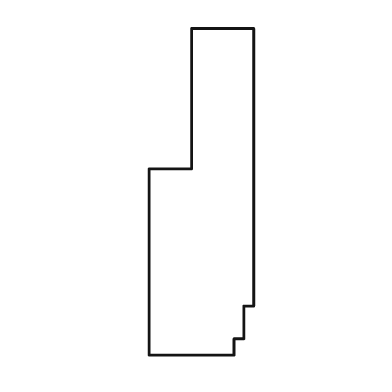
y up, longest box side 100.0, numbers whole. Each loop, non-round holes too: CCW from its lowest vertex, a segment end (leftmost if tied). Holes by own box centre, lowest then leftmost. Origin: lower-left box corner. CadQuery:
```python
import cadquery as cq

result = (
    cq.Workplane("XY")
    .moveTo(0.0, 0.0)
    .lineTo(26.0, 0.0)
    .lineTo(26.0, 5.0)
    .lineTo(29.0, 5.0)
    .lineTo(29.0, 15.0)
    .lineTo(32.0, 15.0)
    .lineTo(32.0, 100.0)
    .lineTo(13.0, 100.0)
    .lineTo(13.0, 57.0)
    .lineTo(0.0, 57.0)
    .close()
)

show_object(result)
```